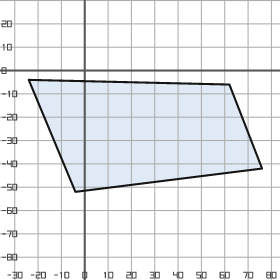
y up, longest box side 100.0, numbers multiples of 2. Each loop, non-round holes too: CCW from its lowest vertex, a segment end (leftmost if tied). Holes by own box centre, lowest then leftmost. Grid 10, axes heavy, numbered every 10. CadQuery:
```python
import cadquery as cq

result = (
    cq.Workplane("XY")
    .moveTo(-4.0, -52.0)
    .lineTo(76.0, -42.0)
    .lineTo(62.0, -6.0)
    .lineTo(-24.0, -4.0)
    .close()
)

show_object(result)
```